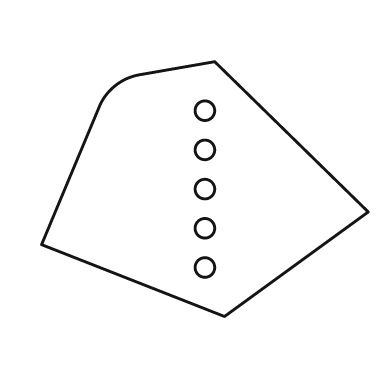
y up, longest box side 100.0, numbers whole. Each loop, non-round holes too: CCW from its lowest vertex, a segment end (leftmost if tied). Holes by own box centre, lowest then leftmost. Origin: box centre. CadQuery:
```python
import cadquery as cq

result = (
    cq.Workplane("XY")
    .moveTo(6.0, -39.0)
    .lineTo(50.0, -7.0)
    .lineTo(3.0, 39.0)
    .lineTo(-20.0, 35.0)
    .threePointArc((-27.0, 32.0), (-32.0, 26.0))
    .lineTo(-50.0, -17.0)
    .close()
    .moveTo(0.0, -24.0)
    .circle(3.0)
    .moveTo(0.0, -12.0)
    .circle(3.0)
    .moveTo(0.0, 0.0)
    .circle(3.0)
    .moveTo(0.0, 12.0)
    .circle(3.0)
    .moveTo(0.0, 24.0)
    .circle(3.0)
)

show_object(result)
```